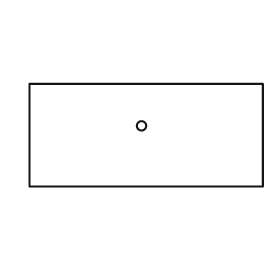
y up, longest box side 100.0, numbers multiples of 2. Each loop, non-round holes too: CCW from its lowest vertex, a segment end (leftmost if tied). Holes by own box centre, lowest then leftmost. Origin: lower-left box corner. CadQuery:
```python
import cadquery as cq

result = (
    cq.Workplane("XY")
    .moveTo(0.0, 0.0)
    .lineTo(100.0, 0.0)
    .lineTo(100.0, 44.0)
    .lineTo(0.0, 44.0)
    .close()
    .moveTo(48.0, 26.0)
    .circle(2.0)
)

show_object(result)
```